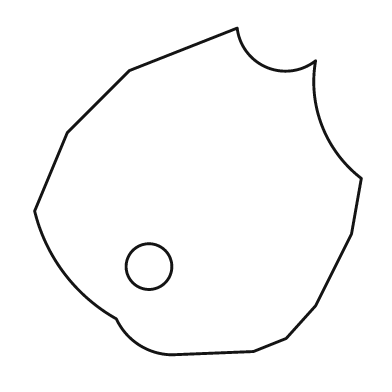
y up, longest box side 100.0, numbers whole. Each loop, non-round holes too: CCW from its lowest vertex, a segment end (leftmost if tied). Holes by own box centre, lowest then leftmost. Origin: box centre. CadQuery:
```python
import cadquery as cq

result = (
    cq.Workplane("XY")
    .moveTo(-8.0, -50.0)
    .lineTo(17.0, -49.0)
    .lineTo(27.0, -45.0)
    .lineTo(36.0, -35.0)
    .lineTo(47.0, -13.0)
    .lineTo(50.0, 4.0)
    .threePointArc((38.0, 20.0), (36.0, 40.0))
    .threePointArc((21.0, 38.0), (12.0, 50.0))
    .lineTo(-21.0, 37.0)
    .lineTo(-40.0, 18.0)
    .lineTo(-50.0, -6.0)
    .threePointArc((-41.0, -25.0), (-25.0, -39.0))
    .threePointArc((-18.0, -47.0), (-8.0, -50.0))
    .close()
    .moveTo(-15.0, -23.0)
    .circle(7.0)
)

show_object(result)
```